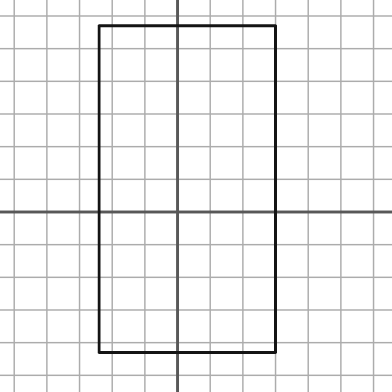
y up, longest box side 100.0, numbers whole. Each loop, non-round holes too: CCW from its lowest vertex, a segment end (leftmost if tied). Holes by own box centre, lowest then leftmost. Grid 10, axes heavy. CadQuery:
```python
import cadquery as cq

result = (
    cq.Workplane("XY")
    .moveTo(-24.0, -43.0)
    .lineTo(30.0, -43.0)
    .lineTo(30.0, 57.0)
    .lineTo(-24.0, 57.0)
    .close()
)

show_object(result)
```